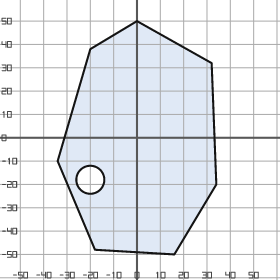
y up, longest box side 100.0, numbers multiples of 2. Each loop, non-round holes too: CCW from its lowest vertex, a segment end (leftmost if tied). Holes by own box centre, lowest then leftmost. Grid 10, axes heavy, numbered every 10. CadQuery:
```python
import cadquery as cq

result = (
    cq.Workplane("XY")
    .moveTo(16.0, -50.0)
    .lineTo(34.0, -20.0)
    .lineTo(32.0, 32.0)
    .lineTo(0.0, 50.0)
    .lineTo(-20.0, 38.0)
    .lineTo(-34.0, -10.0)
    .lineTo(-18.0, -48.0)
    .close()
    .moveTo(-20.0, -18.0)
    .circle(6.0)
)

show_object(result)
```